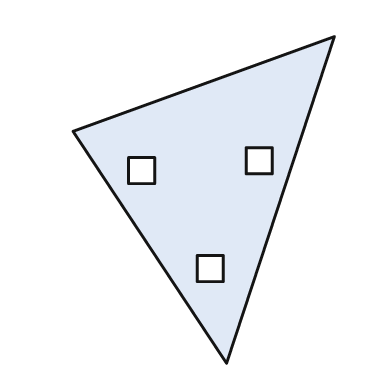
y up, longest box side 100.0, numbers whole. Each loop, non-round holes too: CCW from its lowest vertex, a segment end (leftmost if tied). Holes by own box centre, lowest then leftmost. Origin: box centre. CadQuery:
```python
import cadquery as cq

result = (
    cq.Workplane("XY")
    .moveTo(7.0, -50.0)
    .lineTo(40.0, 50.0)
    .lineTo(-40.0, 21.0)
    .close()
    .moveTo(-2.0, -25.0)
    .lineTo(6.0, -25.0)
    .lineTo(6.0, -17.0)
    .lineTo(-2.0, -17.0)
    .close()
    .moveTo(-23.0, 5.0)
    .lineTo(-15.0, 5.0)
    .lineTo(-15.0, 13.0)
    .lineTo(-23.0, 13.0)
    .close()
    .moveTo(13.0, 8.0)
    .lineTo(21.0, 8.0)
    .lineTo(21.0, 16.0)
    .lineTo(13.0, 16.0)
    .close()
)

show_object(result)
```